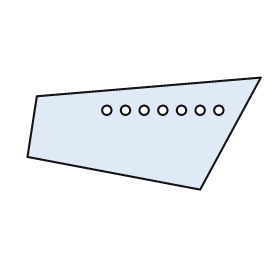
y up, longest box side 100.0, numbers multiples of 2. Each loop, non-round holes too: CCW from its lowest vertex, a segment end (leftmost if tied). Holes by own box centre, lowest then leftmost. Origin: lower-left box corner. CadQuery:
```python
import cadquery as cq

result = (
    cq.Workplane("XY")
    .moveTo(74.0, 0.0)
    .lineTo(100.0, 48.0)
    .lineTo(4.0, 40.0)
    .lineTo(0.0, 14.0)
    .close()
    .moveTo(34.0, 34.0)
    .circle(2.0)
    .moveTo(42.0, 34.0)
    .circle(2.0)
    .moveTo(50.0, 34.0)
    .circle(2.0)
    .moveTo(58.0, 34.0)
    .circle(2.0)
    .moveTo(66.0, 34.0)
    .circle(2.0)
    .moveTo(74.0, 34.0)
    .circle(2.0)
    .moveTo(82.0, 34.0)
    .circle(2.0)
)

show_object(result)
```